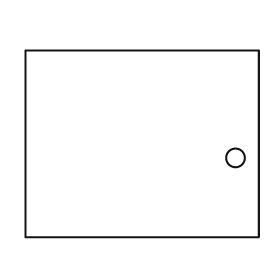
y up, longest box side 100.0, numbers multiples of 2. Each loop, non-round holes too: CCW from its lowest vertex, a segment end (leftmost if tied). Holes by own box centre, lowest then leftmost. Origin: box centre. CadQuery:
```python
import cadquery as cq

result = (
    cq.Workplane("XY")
    .moveTo(-50.0, -40.0)
    .lineTo(50.0, -40.0)
    .lineTo(50.0, 40.0)
    .lineTo(-50.0, 40.0)
    .close()
    .moveTo(40.0, -6.0)
    .circle(4.0)
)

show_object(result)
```